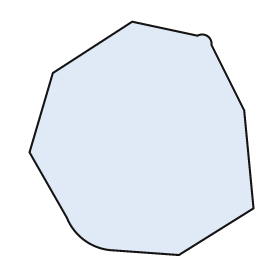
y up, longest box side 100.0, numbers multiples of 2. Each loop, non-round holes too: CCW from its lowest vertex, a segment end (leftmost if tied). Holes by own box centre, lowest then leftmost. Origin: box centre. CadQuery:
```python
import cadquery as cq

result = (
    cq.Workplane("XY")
    .moveTo(16.0, -50.0)
    .lineTo(48.0, -30.0)
    .lineTo(44.0, 12.0)
    .lineTo(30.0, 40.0)
    .threePointArc((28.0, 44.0), (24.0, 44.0))
    .lineTo(-4.0, 50.0)
    .lineTo(-38.0, 28.0)
    .lineTo(-48.0, -6.0)
    .lineTo(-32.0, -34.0)
    .threePointArc((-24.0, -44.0), (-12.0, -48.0))
    .close()
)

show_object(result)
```